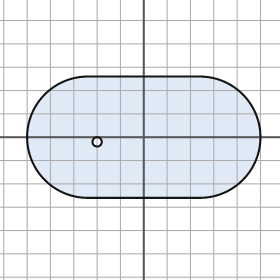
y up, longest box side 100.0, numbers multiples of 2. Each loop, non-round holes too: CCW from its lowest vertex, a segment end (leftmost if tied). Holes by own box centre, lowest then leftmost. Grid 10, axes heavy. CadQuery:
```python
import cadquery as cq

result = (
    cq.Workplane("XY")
    .moveTo(-24.0, -26.0)
    .lineTo(24.0, -26.0)
    .threePointArc((50.0, 0.0), (24.0, 26.0))
    .lineTo(-24.0, 26.0)
    .threePointArc((-50.0, 0.0), (-24.0, -26.0))
    .close()
    .moveTo(-20.0, -2.0)
    .circle(2.0)
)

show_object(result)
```